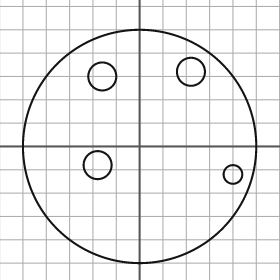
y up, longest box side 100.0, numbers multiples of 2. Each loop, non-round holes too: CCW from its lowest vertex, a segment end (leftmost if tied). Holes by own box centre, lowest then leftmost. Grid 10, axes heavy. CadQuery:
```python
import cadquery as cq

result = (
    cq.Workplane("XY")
    .moveTo(0.0, 0.0)
    .circle(50.0)
    .moveTo(40.0, -12.0)
    .circle(4.0)
    .moveTo(-18.0, -8.0)
    .circle(6.0)
    .moveTo(-16.0, 30.0)
    .circle(6.0)
    .moveTo(22.0, 32.0)
    .circle(6.0)
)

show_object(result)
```